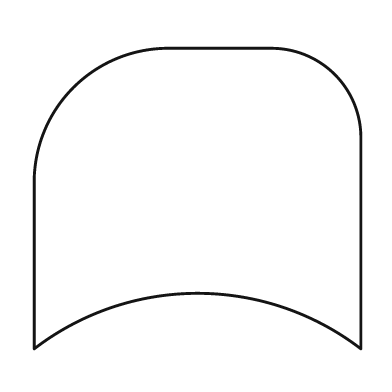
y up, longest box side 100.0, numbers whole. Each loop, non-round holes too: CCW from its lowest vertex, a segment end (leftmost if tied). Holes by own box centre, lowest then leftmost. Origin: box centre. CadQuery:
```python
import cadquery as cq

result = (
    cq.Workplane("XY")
    .moveTo(-50.0, -46.0)
    .threePointArc((0.0, -29.0), (50.0, -46.0))
    .lineTo(50.0, 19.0)
    .threePointArc((42.0, 38.0), (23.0, 46.0))
    .lineTo(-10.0, 46.0)
    .threePointArc((-38.0, 34.0), (-50.0, 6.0))
    .close()
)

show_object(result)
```